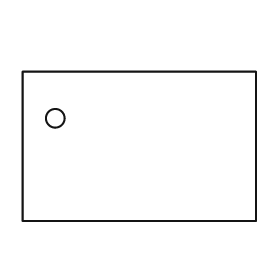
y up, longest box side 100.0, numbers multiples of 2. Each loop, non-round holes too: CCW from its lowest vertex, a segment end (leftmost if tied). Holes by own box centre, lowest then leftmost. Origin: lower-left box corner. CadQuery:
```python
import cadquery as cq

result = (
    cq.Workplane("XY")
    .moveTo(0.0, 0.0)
    .lineTo(100.0, 0.0)
    .lineTo(100.0, 64.0)
    .lineTo(0.0, 64.0)
    .close()
    .moveTo(14.0, 44.0)
    .circle(4.0)
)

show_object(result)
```